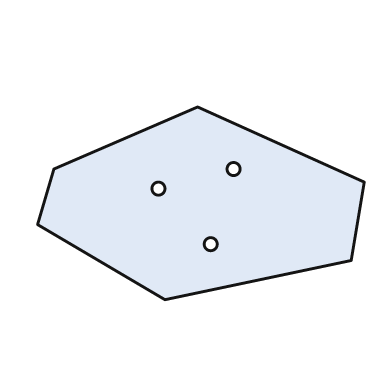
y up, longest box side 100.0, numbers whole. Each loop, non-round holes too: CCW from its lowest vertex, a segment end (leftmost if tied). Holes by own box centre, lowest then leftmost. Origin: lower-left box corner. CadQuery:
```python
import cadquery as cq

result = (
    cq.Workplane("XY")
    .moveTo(39.0, 0.0)
    .lineTo(96.0, 12.0)
    .lineTo(100.0, 36.0)
    .lineTo(49.0, 59.0)
    .lineTo(5.0, 40.0)
    .lineTo(0.0, 23.0)
    .close()
    .moveTo(53.0, 17.0)
    .circle(2.0)
    .moveTo(37.0, 34.0)
    .circle(2.0)
    .moveTo(60.0, 40.0)
    .circle(2.0)
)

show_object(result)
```